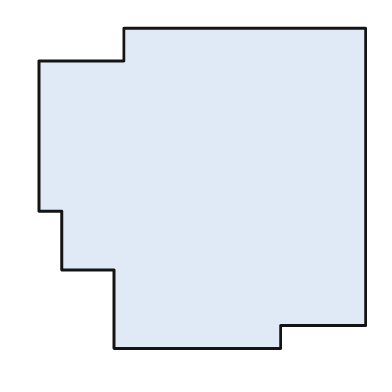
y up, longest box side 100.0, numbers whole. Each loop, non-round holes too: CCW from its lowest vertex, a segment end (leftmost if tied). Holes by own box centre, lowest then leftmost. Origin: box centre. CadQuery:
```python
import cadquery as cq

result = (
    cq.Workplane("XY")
    .moveTo(-27.0, -49.0)
    .lineTo(24.0, -49.0)
    .lineTo(24.0, -42.0)
    .lineTo(50.0, -42.0)
    .lineTo(50.0, 49.0)
    .lineTo(-24.0, 49.0)
    .lineTo(-24.0, 39.0)
    .lineTo(-50.0, 39.0)
    .lineTo(-50.0, -7.0)
    .lineTo(-43.0, -7.0)
    .lineTo(-43.0, -25.0)
    .lineTo(-27.0, -25.0)
    .close()
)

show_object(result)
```